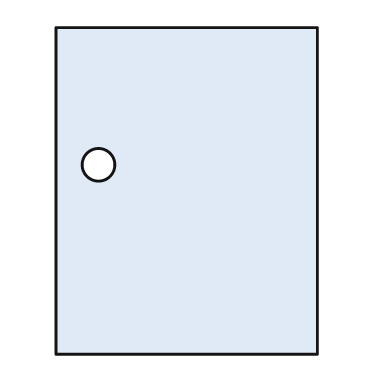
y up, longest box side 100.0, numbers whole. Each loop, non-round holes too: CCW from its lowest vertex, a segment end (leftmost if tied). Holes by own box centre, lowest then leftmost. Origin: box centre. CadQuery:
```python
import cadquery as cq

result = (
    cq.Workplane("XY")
    .moveTo(-40.0, -50.0)
    .lineTo(40.0, -50.0)
    .lineTo(40.0, 50.0)
    .lineTo(-40.0, 50.0)
    .close()
    .moveTo(-27.0, 8.0)
    .circle(5.0)
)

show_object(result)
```